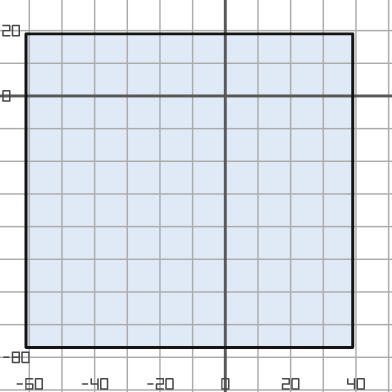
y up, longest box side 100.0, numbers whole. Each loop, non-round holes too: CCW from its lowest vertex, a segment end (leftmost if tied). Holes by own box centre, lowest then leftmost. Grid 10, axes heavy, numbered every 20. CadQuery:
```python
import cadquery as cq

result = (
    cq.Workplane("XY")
    .moveTo(-61.0, -77.0)
    .lineTo(39.0, -77.0)
    .lineTo(39.0, 19.0)
    .lineTo(-61.0, 19.0)
    .close()
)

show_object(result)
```